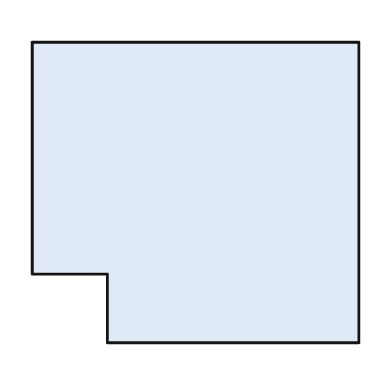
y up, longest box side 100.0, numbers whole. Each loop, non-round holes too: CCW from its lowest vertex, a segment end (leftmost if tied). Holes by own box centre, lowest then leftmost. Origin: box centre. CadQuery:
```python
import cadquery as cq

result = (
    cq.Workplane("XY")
    .moveTo(-27.0, -46.0)
    .lineTo(50.0, -46.0)
    .lineTo(50.0, 46.0)
    .lineTo(-50.0, 46.0)
    .lineTo(-50.0, -25.0)
    .lineTo(-27.0, -25.0)
    .close()
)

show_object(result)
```